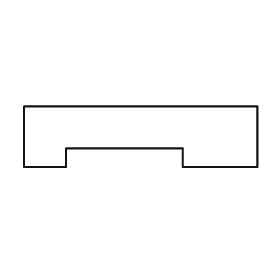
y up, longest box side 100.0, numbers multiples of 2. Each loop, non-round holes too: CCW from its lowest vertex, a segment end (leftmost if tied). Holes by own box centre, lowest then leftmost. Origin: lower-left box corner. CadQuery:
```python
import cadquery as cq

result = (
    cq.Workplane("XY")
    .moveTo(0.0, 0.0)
    .lineTo(18.0, 0.0)
    .lineTo(18.0, 8.0)
    .lineTo(68.0, 8.0)
    .lineTo(68.0, 0.0)
    .lineTo(100.0, 0.0)
    .lineTo(100.0, 26.0)
    .lineTo(0.0, 26.0)
    .close()
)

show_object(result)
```